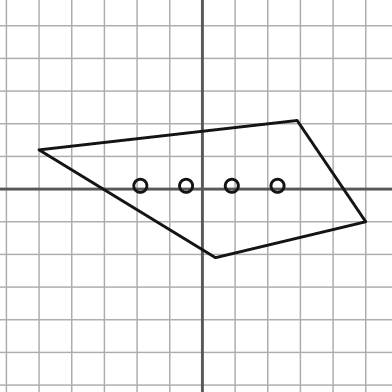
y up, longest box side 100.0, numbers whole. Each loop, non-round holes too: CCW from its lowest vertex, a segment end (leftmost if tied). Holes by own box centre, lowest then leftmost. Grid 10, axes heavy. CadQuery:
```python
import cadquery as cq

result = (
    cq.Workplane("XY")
    .moveTo(4.0, -21.0)
    .lineTo(50.0, -10.0)
    .lineTo(29.0, 21.0)
    .lineTo(-50.0, 12.0)
    .close()
    .moveTo(-19.0, 1.0)
    .circle(2.0)
    .moveTo(-5.0, 1.0)
    .circle(2.0)
    .moveTo(9.0, 1.0)
    .circle(2.0)
    .moveTo(23.0, 1.0)
    .circle(2.0)
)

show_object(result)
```